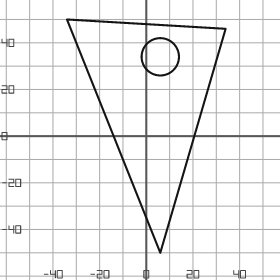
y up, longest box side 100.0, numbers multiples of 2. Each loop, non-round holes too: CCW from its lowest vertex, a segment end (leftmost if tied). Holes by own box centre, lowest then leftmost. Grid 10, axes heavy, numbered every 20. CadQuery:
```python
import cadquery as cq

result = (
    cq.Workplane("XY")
    .moveTo(6.0, -50.0)
    .lineTo(34.0, 46.0)
    .lineTo(-34.0, 50.0)
    .close()
    .moveTo(6.0, 34.0)
    .circle(8.0)
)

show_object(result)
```